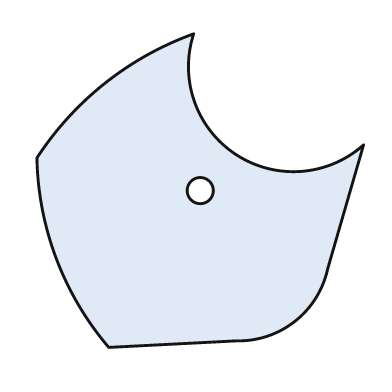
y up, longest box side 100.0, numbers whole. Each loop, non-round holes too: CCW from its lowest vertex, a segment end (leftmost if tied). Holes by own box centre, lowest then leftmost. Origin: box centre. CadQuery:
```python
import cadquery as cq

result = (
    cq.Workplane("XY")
    .moveTo(-28.0, -48.0)
    .lineTo(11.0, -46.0)
    .threePointArc((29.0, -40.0), (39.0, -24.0))
    .lineTo(50.0, 14.0)
    .threePointArc((11.0, 11.0), (-2.0, 48.0))
    .threePointArc((-29.0, 33.0), (-50.0, 10.0))
    .threePointArc((-44.0, -21.0), (-28.0, -48.0))
    .close()
    .moveTo(0.0, 0.0)
    .circle(4.0)
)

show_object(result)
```